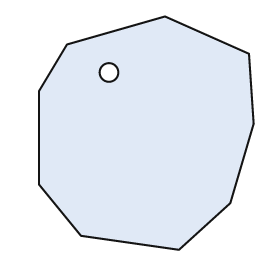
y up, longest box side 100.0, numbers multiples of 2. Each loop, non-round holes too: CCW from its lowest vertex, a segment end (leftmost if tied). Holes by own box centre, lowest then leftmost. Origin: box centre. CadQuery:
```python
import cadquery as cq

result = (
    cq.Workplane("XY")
    .moveTo(14.0, -50.0)
    .lineTo(36.0, -30.0)
    .lineTo(46.0, 4.0)
    .lineTo(44.0, 34.0)
    .lineTo(8.0, 50.0)
    .lineTo(-34.0, 38.0)
    .lineTo(-46.0, 18.0)
    .lineTo(-46.0, -22.0)
    .lineTo(-28.0, -44.0)
    .close()
    .moveTo(-16.0, 26.0)
    .circle(4.0)
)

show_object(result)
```